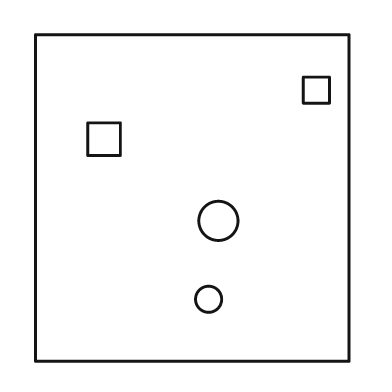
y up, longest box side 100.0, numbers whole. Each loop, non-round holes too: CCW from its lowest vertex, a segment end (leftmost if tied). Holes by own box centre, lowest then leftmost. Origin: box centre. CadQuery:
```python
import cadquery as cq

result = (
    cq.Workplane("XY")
    .moveTo(-48.0, -50.0)
    .lineTo(48.0, -50.0)
    .lineTo(48.0, 50.0)
    .lineTo(-48.0, 50.0)
    .close()
    .moveTo(5.0, -31.0)
    .circle(4.0)
    .moveTo(8.0, -7.0)
    .circle(6.0)
    .moveTo(-32.0, 13.0)
    .lineTo(-22.0, 13.0)
    .lineTo(-22.0, 23.0)
    .lineTo(-32.0, 23.0)
    .close()
    .moveTo(34.0, 29.0)
    .lineTo(42.0, 29.0)
    .lineTo(42.0, 37.0)
    .lineTo(34.0, 37.0)
    .close()
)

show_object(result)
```